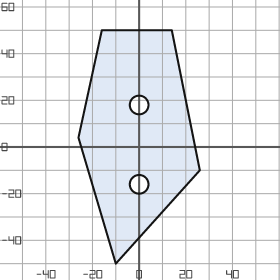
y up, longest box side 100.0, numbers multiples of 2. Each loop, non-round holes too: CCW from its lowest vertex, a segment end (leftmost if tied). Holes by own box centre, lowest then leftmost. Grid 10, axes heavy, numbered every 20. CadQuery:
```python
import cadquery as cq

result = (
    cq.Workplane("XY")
    .moveTo(-10.0, -50.0)
    .lineTo(26.0, -10.0)
    .lineTo(14.0, 50.0)
    .lineTo(-16.0, 50.0)
    .lineTo(-26.0, 4.0)
    .close()
    .moveTo(0.0, -16.0)
    .circle(4.0)
    .moveTo(0.0, 18.0)
    .circle(4.0)
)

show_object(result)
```